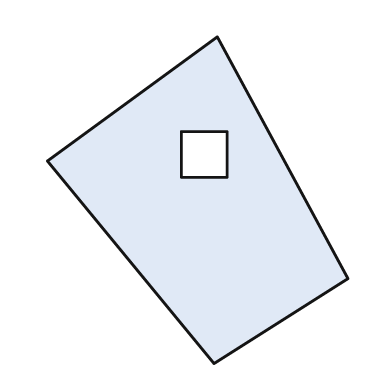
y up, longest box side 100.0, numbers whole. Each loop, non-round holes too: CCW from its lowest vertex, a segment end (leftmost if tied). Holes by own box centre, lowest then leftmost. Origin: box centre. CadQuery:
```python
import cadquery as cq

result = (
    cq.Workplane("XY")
    .moveTo(5.0, -50.0)
    .lineTo(46.0, -24.0)
    .lineTo(6.0, 50.0)
    .lineTo(-46.0, 12.0)
    .close()
    .moveTo(-5.0, 7.0)
    .lineTo(9.0, 7.0)
    .lineTo(9.0, 21.0)
    .lineTo(-5.0, 21.0)
    .close()
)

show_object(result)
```